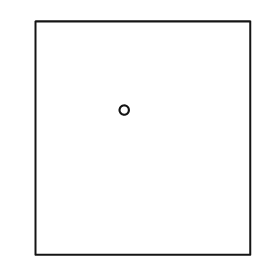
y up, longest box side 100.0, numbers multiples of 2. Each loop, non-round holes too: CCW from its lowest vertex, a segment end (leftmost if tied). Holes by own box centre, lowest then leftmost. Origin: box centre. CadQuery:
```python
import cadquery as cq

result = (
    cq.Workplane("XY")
    .moveTo(-46.0, -50.0)
    .lineTo(46.0, -50.0)
    .lineTo(46.0, 50.0)
    .lineTo(-46.0, 50.0)
    .close()
    .moveTo(-8.0, 12.0)
    .circle(2.0)
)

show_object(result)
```